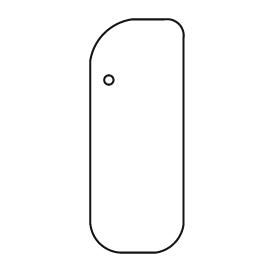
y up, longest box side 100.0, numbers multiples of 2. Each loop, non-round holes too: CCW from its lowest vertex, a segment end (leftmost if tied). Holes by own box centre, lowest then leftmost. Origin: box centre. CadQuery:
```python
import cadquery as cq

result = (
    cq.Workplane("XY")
    .moveTo(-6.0, -50.0)
    .lineTo(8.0, -50.0)
    .threePointArc((16.0, -46.0), (20.0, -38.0))
    .lineTo(20.0, 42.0)
    .threePointArc((18.0, 48.0), (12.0, 50.0))
    .lineTo(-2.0, 50.0)
    .threePointArc((-14.0, 44.0), (-20.0, 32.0))
    .lineTo(-20.0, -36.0)
    .threePointArc((-16.0, -46.0), (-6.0, -50.0))
    .close()
    .moveTo(-12.0, 24.0)
    .circle(2.0)
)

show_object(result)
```